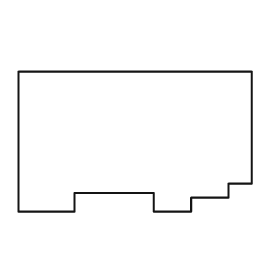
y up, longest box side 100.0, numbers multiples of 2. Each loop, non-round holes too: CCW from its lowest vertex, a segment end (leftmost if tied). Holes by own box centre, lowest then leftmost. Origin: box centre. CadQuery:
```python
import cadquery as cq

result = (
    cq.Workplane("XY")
    .moveTo(-50.0, -30.0)
    .lineTo(-26.0, -30.0)
    .lineTo(-26.0, -22.0)
    .lineTo(8.0, -22.0)
    .lineTo(8.0, -30.0)
    .lineTo(24.0, -30.0)
    .lineTo(24.0, -24.0)
    .lineTo(40.0, -24.0)
    .lineTo(40.0, -18.0)
    .lineTo(50.0, -18.0)
    .lineTo(50.0, 30.0)
    .lineTo(-50.0, 30.0)
    .close()
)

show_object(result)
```